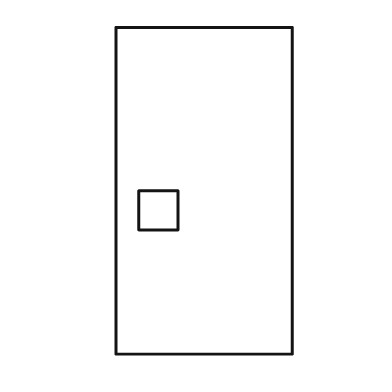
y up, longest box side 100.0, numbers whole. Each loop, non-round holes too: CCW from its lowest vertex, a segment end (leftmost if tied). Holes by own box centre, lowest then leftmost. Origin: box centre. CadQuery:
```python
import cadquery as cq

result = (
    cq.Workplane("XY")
    .moveTo(-27.0, -50.0)
    .lineTo(27.0, -50.0)
    .lineTo(27.0, 50.0)
    .lineTo(-27.0, 50.0)
    .close()
    .moveTo(-20.0, -12.0)
    .lineTo(-8.0, -12.0)
    .lineTo(-8.0, 0.0)
    .lineTo(-20.0, 0.0)
    .close()
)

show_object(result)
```